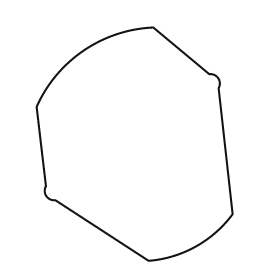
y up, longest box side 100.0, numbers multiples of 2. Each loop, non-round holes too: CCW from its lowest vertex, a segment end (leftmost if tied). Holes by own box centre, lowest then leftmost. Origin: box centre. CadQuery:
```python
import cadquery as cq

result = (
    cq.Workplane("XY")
    .moveTo(6.0, -50.0)
    .threePointArc((26.0, -44.0), (42.0, -30.0))
    .lineTo(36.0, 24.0)
    .threePointArc((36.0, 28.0), (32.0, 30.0))
    .lineTo(8.0, 50.0)
    .threePointArc((-22.0, 40.0), (-42.0, 16.0))
    .lineTo(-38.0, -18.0)
    .threePointArc((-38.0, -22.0), (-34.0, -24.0))
    .close()
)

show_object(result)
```